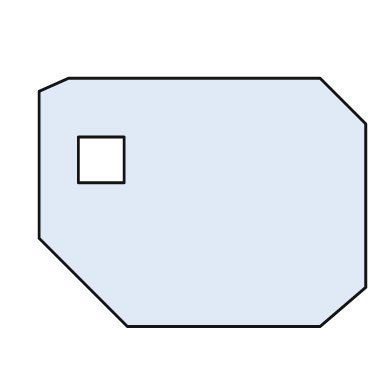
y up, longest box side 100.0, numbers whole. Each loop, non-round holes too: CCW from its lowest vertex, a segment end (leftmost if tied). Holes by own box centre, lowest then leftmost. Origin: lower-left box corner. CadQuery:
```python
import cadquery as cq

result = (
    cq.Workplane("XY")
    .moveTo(27.0, 0.0)
    .lineTo(86.0, 0.0)
    .lineTo(100.0, 12.0)
    .lineTo(100.0, 62.0)
    .lineTo(86.0, 76.0)
    .lineTo(9.0, 76.0)
    .lineTo(0.0, 72.0)
    .lineTo(0.0, 27.0)
    .close()
    .moveTo(12.0, 44.0)
    .lineTo(26.0, 44.0)
    .lineTo(26.0, 58.0)
    .lineTo(12.0, 58.0)
    .close()
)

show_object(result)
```